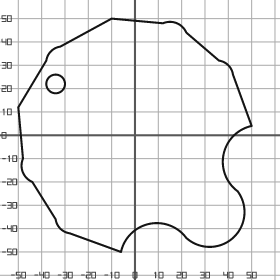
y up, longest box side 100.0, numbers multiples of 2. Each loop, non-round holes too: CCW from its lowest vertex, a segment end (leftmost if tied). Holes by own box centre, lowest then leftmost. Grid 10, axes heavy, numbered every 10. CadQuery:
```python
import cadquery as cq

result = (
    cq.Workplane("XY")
    .moveTo(-6.0, -50.0)
    .threePointArc((6.0, -38.0), (22.0, -44.0))
    .threePointArc((42.0, -44.0), (44.0, -24.0))
    .threePointArc((38.0, -8.0), (50.0, 4.0))
    .lineTo(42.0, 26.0)
    .threePointArc((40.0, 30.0), (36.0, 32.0))
    .lineTo(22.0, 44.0)
    .threePointArc((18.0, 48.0), (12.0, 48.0))
    .lineTo(-10.0, 50.0)
    .lineTo(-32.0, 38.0)
    .threePointArc((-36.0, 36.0), (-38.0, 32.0))
    .lineTo(-50.0, 12.0)
    .lineTo(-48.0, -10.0)
    .threePointArc((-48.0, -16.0), (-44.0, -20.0))
    .lineTo(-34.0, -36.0)
    .threePointArc((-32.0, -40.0), (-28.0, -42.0))
    .close()
    .moveTo(-34.0, 22.0)
    .circle(4.0)
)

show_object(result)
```